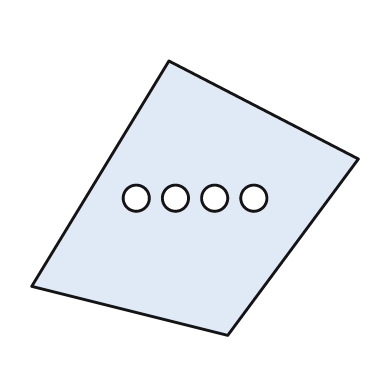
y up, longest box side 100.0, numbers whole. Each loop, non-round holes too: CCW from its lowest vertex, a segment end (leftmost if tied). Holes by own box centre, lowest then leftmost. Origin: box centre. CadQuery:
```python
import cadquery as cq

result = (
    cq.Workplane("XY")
    .moveTo(10.0, -42.0)
    .lineTo(50.0, 12.0)
    .lineTo(-8.0, 42.0)
    .lineTo(-50.0, -27.0)
    .close()
    .moveTo(-18.0, 0.0)
    .circle(4.0)
    .moveTo(-6.0, 0.0)
    .circle(4.0)
    .moveTo(6.0, 0.0)
    .circle(4.0)
    .moveTo(18.0, 0.0)
    .circle(4.0)
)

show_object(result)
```